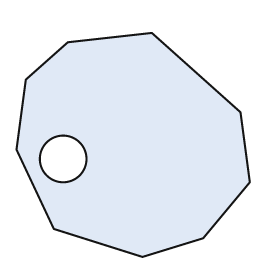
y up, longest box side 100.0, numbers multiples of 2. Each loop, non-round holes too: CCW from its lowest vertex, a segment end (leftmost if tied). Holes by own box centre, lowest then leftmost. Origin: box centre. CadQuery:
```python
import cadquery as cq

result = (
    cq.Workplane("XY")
    .moveTo(4.0, -48.0)
    .lineTo(30.0, -40.0)
    .lineTo(50.0, -16.0)
    .lineTo(46.0, 14.0)
    .lineTo(8.0, 48.0)
    .lineTo(-28.0, 44.0)
    .lineTo(-46.0, 28.0)
    .lineTo(-50.0, -2.0)
    .lineTo(-34.0, -36.0)
    .close()
    .moveTo(-30.0, -6.0)
    .circle(10.0)
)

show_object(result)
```